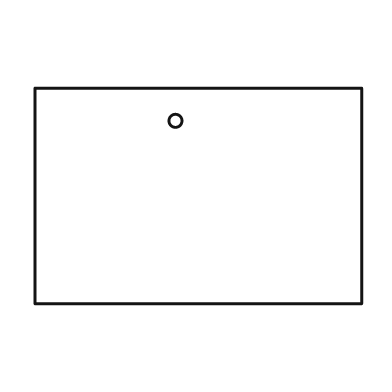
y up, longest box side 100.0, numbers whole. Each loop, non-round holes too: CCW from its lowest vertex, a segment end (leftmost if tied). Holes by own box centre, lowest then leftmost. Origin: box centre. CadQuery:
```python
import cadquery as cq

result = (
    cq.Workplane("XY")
    .moveTo(-50.0, -33.0)
    .lineTo(50.0, -33.0)
    .lineTo(50.0, 33.0)
    .lineTo(-50.0, 33.0)
    .close()
    .moveTo(-7.0, 23.0)
    .circle(2.0)
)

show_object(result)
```